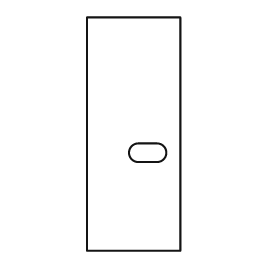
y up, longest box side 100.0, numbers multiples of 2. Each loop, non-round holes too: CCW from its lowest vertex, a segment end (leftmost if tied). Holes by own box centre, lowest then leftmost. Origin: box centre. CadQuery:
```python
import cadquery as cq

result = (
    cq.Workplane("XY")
    .moveTo(-20.0, -50.0)
    .lineTo(20.0, -50.0)
    .lineTo(20.0, 50.0)
    .lineTo(-20.0, 50.0)
    .close()
    .moveTo(2.0, -12.0)
    .lineTo(10.0, -12.0)
    .threePointArc((14.0, -8.0), (10.0, -4.0))
    .lineTo(2.0, -4.0)
    .threePointArc((-2.0, -8.0), (2.0, -12.0))
    .close()
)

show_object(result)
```